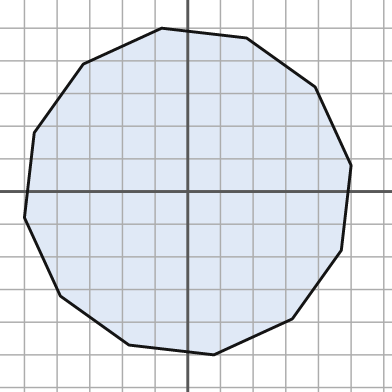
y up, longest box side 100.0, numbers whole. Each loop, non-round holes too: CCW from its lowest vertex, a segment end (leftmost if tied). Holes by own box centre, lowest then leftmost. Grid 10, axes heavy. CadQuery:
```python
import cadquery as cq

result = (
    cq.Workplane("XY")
    .moveTo(8.0, -50.0)
    .lineTo(32.0, -39.0)
    .lineTo(47.0, -18.0)
    .lineTo(50.0, 8.0)
    .lineTo(39.0, 32.0)
    .lineTo(18.0, 47.0)
    .lineTo(-8.0, 50.0)
    .lineTo(-32.0, 39.0)
    .lineTo(-47.0, 18.0)
    .lineTo(-50.0, -8.0)
    .lineTo(-39.0, -32.0)
    .lineTo(-18.0, -47.0)
    .close()
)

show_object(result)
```